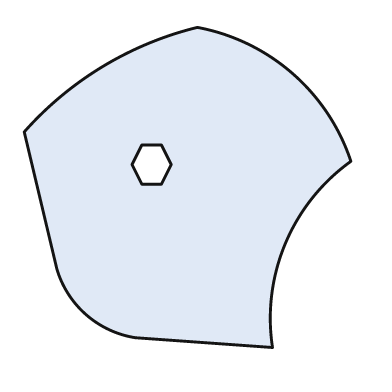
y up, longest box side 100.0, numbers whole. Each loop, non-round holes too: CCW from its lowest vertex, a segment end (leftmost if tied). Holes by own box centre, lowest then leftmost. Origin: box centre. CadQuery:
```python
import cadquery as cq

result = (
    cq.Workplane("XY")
    .moveTo(26.0, -49.0)
    .threePointArc((30.0, -17.0), (50.0, 8.0))
    .threePointArc((32.0, 35.0), (3.0, 49.0))
    .threePointArc((-26.0, 37.0), (-50.0, 17.0))
    .lineTo(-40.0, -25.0)
    .threePointArc((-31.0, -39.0), (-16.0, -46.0))
    .close()
    .moveTo(-14.0, 1.0)
    .lineTo(-8.0, 1.0)
    .lineTo(-5.0, 7.0)
    .lineTo(-8.0, 13.0)
    .lineTo(-14.0, 13.0)
    .lineTo(-17.0, 7.0)
    .close()
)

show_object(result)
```